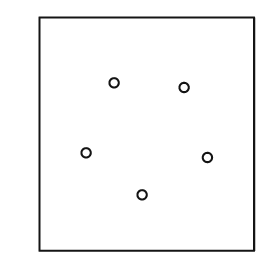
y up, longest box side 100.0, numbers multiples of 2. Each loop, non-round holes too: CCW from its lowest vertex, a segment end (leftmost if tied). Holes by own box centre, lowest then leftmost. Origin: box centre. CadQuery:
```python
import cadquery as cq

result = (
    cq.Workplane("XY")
    .moveTo(-46.0, -50.0)
    .lineTo(46.0, -50.0)
    .lineTo(46.0, 50.0)
    .lineTo(-46.0, 50.0)
    .close()
    .moveTo(-2.0, -26.0)
    .circle(2.0)
    .moveTo(26.0, -10.0)
    .circle(2.0)
    .moveTo(-26.0, -8.0)
    .circle(2.0)
    .moveTo(16.0, 20.0)
    .circle(2.0)
    .moveTo(-14.0, 22.0)
    .circle(2.0)
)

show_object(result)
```